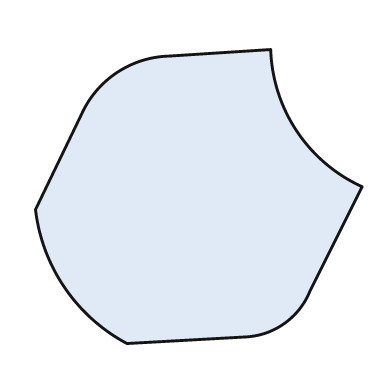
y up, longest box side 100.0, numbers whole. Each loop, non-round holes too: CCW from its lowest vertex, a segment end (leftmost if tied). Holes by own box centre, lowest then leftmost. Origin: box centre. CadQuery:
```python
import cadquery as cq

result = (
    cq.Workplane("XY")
    .moveTo(-22.0, -45.0)
    .lineTo(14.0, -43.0)
    .threePointArc((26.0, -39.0), (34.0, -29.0))
    .lineTo(50.0, 3.0)
    .threePointArc((30.0, 20.0), (22.0, 45.0))
    .lineTo(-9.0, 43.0)
    .threePointArc((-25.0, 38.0), (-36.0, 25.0))
    .lineTo(-50.0, -4.0)
    .threePointArc((-41.0, -28.0), (-22.0, -45.0))
    .close()
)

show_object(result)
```